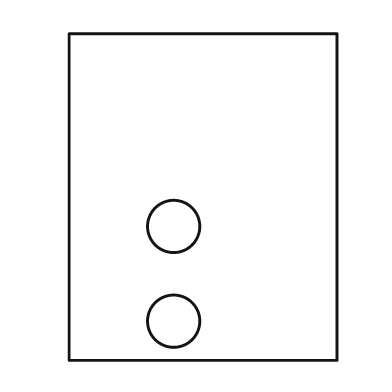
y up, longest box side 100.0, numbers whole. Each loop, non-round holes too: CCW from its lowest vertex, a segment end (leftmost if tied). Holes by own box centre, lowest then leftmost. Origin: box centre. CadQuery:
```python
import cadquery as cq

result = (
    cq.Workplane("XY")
    .moveTo(-41.0, -50.0)
    .lineTo(41.0, -50.0)
    .lineTo(41.0, 50.0)
    .lineTo(-41.0, 50.0)
    .close()
    .moveTo(-9.0, -38.0)
    .circle(8.0)
    .moveTo(-9.0, -9.0)
    .circle(8.0)
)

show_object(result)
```